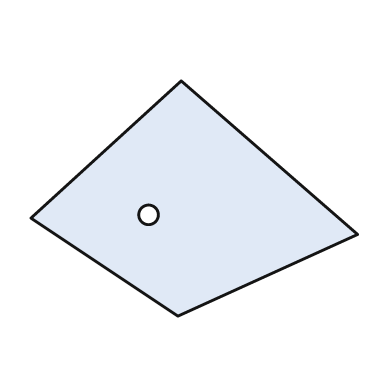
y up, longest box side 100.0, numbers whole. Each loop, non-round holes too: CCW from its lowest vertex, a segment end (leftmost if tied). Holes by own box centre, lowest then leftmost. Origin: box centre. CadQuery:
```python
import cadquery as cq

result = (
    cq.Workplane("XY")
    .moveTo(-5.0, -36.0)
    .lineTo(50.0, -11.0)
    .lineTo(-4.0, 36.0)
    .lineTo(-50.0, -6.0)
    .close()
    .moveTo(-14.0, -5.0)
    .circle(3.0)
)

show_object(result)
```